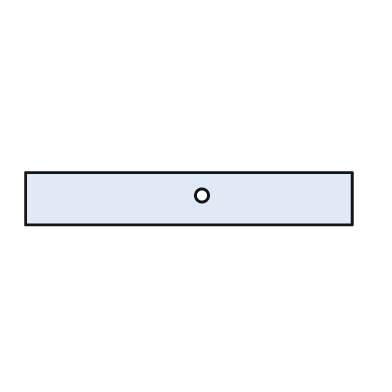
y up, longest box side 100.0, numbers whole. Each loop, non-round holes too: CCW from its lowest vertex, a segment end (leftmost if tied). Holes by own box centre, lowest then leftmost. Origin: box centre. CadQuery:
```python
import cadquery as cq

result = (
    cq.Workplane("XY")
    .moveTo(-50.0, -8.0)
    .lineTo(50.0, -8.0)
    .lineTo(50.0, 8.0)
    .lineTo(-50.0, 8.0)
    .close()
    .moveTo(4.0, 1.0)
    .circle(2.0)
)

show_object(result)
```